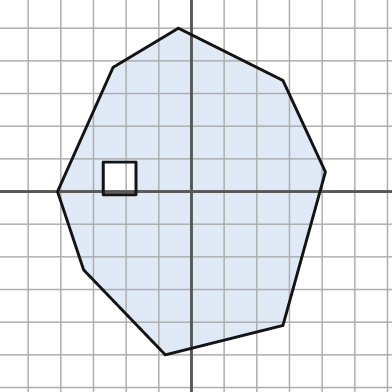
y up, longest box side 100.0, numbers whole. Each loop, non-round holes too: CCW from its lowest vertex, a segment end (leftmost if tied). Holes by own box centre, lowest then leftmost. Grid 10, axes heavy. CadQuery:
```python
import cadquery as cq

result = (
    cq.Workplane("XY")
    .moveTo(-8.0, -50.0)
    .lineTo(28.0, -41.0)
    .lineTo(41.0, 6.0)
    .lineTo(28.0, 34.0)
    .lineTo(-4.0, 50.0)
    .lineTo(-24.0, 38.0)
    .lineTo(-41.0, 0.0)
    .lineTo(-33.0, -24.0)
    .close()
    .moveTo(-27.0, -1.0)
    .lineTo(-17.0, -1.0)
    .lineTo(-17.0, 9.0)
    .lineTo(-27.0, 9.0)
    .close()
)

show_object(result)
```